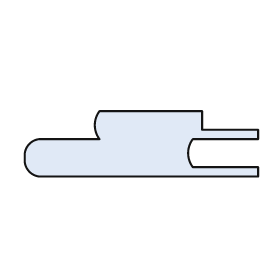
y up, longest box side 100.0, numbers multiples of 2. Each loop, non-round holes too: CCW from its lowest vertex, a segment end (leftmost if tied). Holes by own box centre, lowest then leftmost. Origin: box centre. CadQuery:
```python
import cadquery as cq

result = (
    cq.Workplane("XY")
    .moveTo(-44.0, -14.0)
    .lineTo(50.0, -14.0)
    .lineTo(50.0, -10.0)
    .lineTo(22.0, -10.0)
    .threePointArc((20.0, -4.0), (22.0, 2.0))
    .lineTo(50.0, 2.0)
    .lineTo(50.0, 6.0)
    .lineTo(26.0, 6.0)
    .lineTo(26.0, 14.0)
    .lineTo(-18.0, 14.0)
    .threePointArc((-20.0, 8.0), (-18.0, 2.0))
    .lineTo(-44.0, 2.0)
    .threePointArc((-48.0, 0.0), (-50.0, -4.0))
    .lineTo(-50.0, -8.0)
    .threePointArc((-48.0, -12.0), (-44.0, -14.0))
    .close()
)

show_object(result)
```